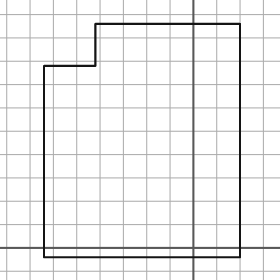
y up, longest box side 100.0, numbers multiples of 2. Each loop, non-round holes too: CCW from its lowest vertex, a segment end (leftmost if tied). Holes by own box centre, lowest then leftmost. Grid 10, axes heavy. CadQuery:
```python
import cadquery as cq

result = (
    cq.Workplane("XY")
    .moveTo(-64.0, -4.0)
    .lineTo(20.0, -4.0)
    .lineTo(20.0, 96.0)
    .lineTo(-42.0, 96.0)
    .lineTo(-42.0, 78.0)
    .lineTo(-64.0, 78.0)
    .close()
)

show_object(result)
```